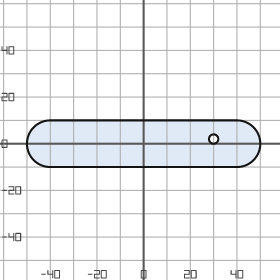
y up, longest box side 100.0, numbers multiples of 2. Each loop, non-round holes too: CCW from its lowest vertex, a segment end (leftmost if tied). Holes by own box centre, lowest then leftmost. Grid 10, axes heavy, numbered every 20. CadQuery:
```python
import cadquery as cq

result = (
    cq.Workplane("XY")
    .moveTo(-40.0, -10.0)
    .lineTo(40.0, -10.0)
    .threePointArc((50.0, 0.0), (40.0, 10.0))
    .lineTo(-40.0, 10.0)
    .threePointArc((-50.0, 0.0), (-40.0, -10.0))
    .close()
    .moveTo(30.0, 2.0)
    .circle(2.0)
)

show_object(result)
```